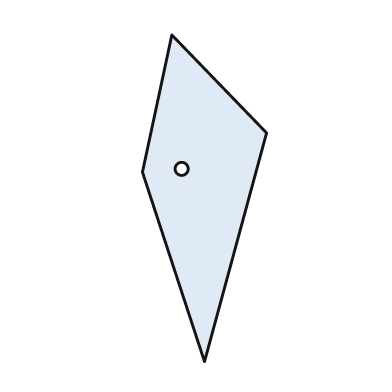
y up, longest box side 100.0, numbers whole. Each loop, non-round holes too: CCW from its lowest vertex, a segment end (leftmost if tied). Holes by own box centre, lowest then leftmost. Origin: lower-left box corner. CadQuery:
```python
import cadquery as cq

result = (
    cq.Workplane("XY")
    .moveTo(19.0, 0.0)
    .lineTo(38.0, 70.0)
    .lineTo(9.0, 100.0)
    .lineTo(0.0, 58.0)
    .close()
    .moveTo(12.0, 59.0)
    .circle(2.0)
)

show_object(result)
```